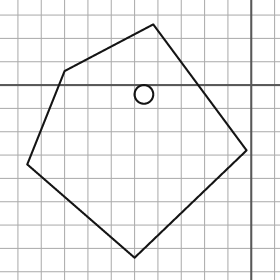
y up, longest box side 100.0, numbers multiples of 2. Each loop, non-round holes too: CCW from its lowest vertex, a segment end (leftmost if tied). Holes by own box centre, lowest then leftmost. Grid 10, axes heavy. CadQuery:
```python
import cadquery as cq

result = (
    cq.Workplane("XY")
    .moveTo(-50.0, -74.0)
    .lineTo(-2.0, -28.0)
    .lineTo(-42.0, 26.0)
    .lineTo(-80.0, 6.0)
    .lineTo(-96.0, -34.0)
    .close()
    .moveTo(-46.0, -4.0)
    .circle(4.0)
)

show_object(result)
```